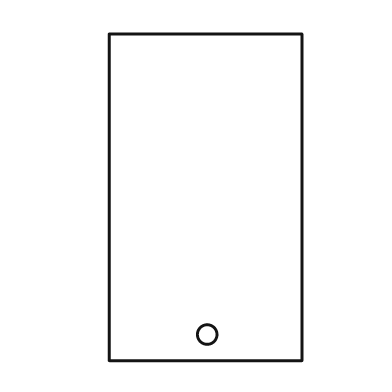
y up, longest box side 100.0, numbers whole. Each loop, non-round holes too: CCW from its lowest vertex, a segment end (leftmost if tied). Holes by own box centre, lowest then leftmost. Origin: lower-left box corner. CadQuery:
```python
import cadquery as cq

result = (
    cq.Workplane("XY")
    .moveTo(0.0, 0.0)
    .lineTo(59.0, 0.0)
    .lineTo(59.0, 100.0)
    .lineTo(0.0, 100.0)
    .close()
    .moveTo(30.0, 8.0)
    .circle(3.0)
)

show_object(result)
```